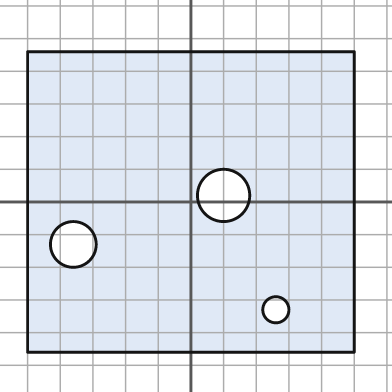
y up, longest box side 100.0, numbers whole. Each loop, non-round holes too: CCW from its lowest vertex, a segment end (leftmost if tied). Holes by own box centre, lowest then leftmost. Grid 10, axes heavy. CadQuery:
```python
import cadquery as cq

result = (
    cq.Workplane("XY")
    .moveTo(-50.0, -46.0)
    .lineTo(50.0, -46.0)
    .lineTo(50.0, 46.0)
    .lineTo(-50.0, 46.0)
    .close()
    .moveTo(26.0, -33.0)
    .circle(4.0)
    .moveTo(-36.0, -13.0)
    .circle(7.0)
    .moveTo(10.0, 2.0)
    .circle(8.0)
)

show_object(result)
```